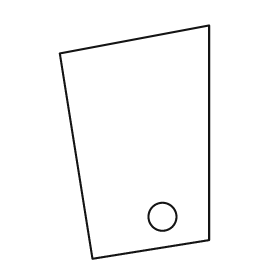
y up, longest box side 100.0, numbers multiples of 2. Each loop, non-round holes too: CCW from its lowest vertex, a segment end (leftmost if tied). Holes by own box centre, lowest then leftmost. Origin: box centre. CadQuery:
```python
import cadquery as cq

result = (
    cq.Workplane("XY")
    .moveTo(-18.0, -50.0)
    .lineTo(32.0, -42.0)
    .lineTo(32.0, 50.0)
    .lineTo(-32.0, 38.0)
    .close()
    .moveTo(12.0, -32.0)
    .circle(6.0)
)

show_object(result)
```